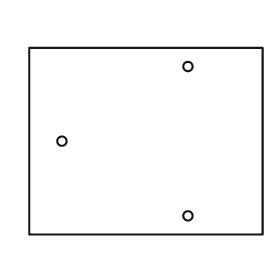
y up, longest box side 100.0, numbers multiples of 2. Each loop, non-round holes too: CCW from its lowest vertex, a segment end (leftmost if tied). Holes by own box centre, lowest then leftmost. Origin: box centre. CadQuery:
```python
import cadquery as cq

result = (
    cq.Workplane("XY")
    .moveTo(-50.0, -40.0)
    .lineTo(50.0, -40.0)
    .lineTo(50.0, 40.0)
    .lineTo(-50.0, 40.0)
    .close()
    .moveTo(18.0, -32.0)
    .circle(2.0)
    .moveTo(-36.0, 0.0)
    .circle(2.0)
    .moveTo(18.0, 32.0)
    .circle(2.0)
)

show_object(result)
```